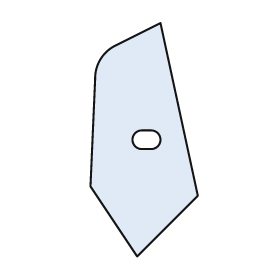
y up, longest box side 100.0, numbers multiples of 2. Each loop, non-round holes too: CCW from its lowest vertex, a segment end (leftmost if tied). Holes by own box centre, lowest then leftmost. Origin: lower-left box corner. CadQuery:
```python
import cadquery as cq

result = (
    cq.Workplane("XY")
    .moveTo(20.0, 0.0)
    .lineTo(46.0, 26.0)
    .lineTo(30.0, 100.0)
    .lineTo(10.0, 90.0)
    .threePointArc((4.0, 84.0), (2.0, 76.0))
    .lineTo(0.0, 30.0)
    .close()
    .moveTo(22.0, 46.0)
    .lineTo(26.0, 46.0)
    .threePointArc((30.0, 50.0), (26.0, 54.0))
    .lineTo(22.0, 54.0)
    .threePointArc((18.0, 50.0), (22.0, 46.0))
    .close()
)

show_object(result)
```